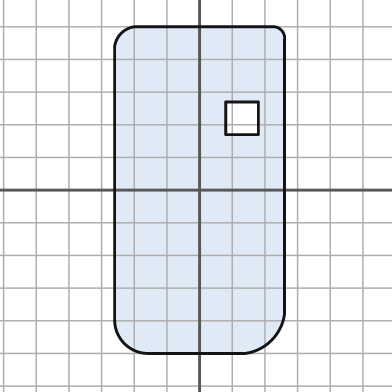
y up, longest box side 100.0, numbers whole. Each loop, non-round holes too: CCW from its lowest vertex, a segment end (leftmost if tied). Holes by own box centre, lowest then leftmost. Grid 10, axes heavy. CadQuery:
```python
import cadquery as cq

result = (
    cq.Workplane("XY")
    .moveTo(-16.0, -50.0)
    .lineTo(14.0, -50.0)
    .threePointArc((22.0, -46.0), (26.0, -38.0))
    .lineTo(26.0, 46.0)
    .threePointArc((25.0, 49.0), (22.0, 50.0))
    .lineTo(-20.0, 50.0)
    .threePointArc((-24.0, 48.0), (-26.0, 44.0))
    .lineTo(-26.0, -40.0)
    .threePointArc((-23.0, -47.0), (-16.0, -50.0))
    .close()
    .moveTo(8.0, 17.0)
    .lineTo(18.0, 17.0)
    .lineTo(18.0, 27.0)
    .lineTo(8.0, 27.0)
    .close()
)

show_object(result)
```